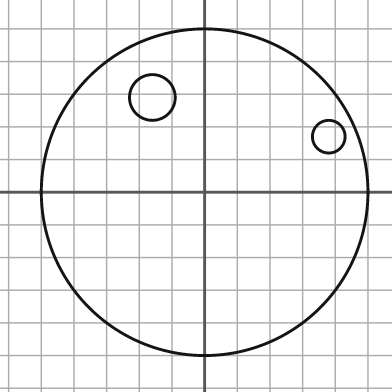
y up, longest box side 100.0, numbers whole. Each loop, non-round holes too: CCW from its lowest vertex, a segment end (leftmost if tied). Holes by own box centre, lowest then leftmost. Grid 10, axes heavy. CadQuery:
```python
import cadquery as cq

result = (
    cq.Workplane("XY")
    .moveTo(0.0, 0.0)
    .circle(50.0)
    .moveTo(38.0, 17.0)
    .circle(5.0)
    .moveTo(-16.0, 29.0)
    .circle(7.0)
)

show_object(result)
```